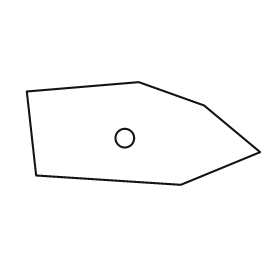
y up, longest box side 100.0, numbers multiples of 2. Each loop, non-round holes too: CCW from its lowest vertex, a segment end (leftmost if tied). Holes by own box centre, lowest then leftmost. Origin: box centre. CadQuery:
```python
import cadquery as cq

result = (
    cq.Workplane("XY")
    .moveTo(16.0, -22.0)
    .lineTo(50.0, -8.0)
    .lineTo(26.0, 12.0)
    .lineTo(-2.0, 22.0)
    .lineTo(-50.0, 18.0)
    .lineTo(-46.0, -18.0)
    .close()
    .moveTo(-8.0, -2.0)
    .circle(4.0)
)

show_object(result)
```